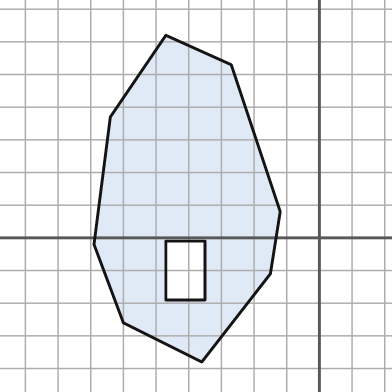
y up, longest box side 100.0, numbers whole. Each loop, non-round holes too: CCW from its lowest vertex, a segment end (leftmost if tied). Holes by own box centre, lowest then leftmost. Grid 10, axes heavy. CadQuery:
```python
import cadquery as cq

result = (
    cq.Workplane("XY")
    .moveTo(-36.0, -38.0)
    .lineTo(-15.0, -11.0)
    .lineTo(-12.0, 8.0)
    .lineTo(-27.0, 53.0)
    .lineTo(-47.0, 62.0)
    .lineTo(-64.0, 37.0)
    .lineTo(-69.0, -2.0)
    .lineTo(-60.0, -26.0)
    .close()
    .moveTo(-47.0, -19.0)
    .lineTo(-35.0, -19.0)
    .lineTo(-35.0, -1.0)
    .lineTo(-47.0, -1.0)
    .close()
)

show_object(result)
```